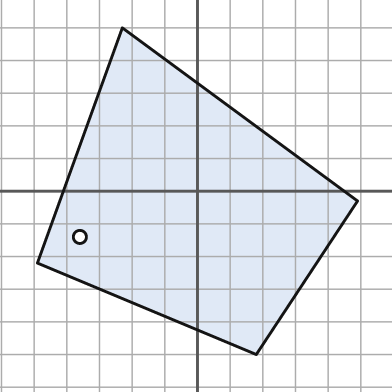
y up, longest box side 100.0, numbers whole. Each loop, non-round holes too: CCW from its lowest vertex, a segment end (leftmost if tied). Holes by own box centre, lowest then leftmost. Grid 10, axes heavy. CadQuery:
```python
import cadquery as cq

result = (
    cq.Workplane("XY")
    .moveTo(18.0, -50.0)
    .lineTo(49.0, -3.0)
    .lineTo(-23.0, 50.0)
    .lineTo(-49.0, -22.0)
    .close()
    .moveTo(-36.0, -14.0)
    .circle(2.0)
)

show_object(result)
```